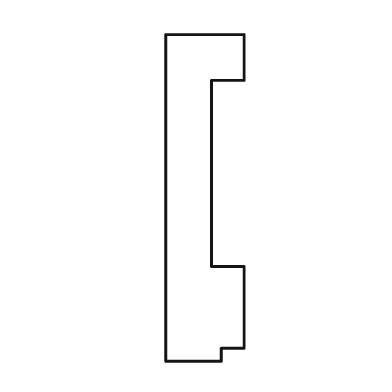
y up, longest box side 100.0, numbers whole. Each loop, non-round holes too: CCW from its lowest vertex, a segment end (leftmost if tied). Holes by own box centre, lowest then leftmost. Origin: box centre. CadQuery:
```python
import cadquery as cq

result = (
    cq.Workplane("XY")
    .moveTo(-12.0, -50.0)
    .lineTo(5.0, -50.0)
    .lineTo(5.0, -46.0)
    .lineTo(12.0, -46.0)
    .lineTo(12.0, -21.0)
    .lineTo(2.0, -21.0)
    .lineTo(2.0, 36.0)
    .lineTo(12.0, 36.0)
    .lineTo(12.0, 50.0)
    .lineTo(-12.0, 50.0)
    .close()
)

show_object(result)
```